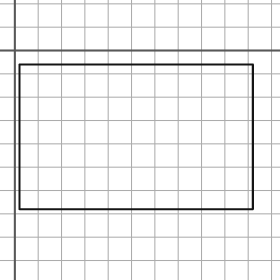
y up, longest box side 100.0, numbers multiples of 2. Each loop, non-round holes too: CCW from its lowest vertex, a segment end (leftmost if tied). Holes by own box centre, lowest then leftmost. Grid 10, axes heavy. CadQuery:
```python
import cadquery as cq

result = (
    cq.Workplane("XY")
    .moveTo(2.0, -68.0)
    .lineTo(102.0, -68.0)
    .lineTo(102.0, -6.0)
    .lineTo(2.0, -6.0)
    .close()
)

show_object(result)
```